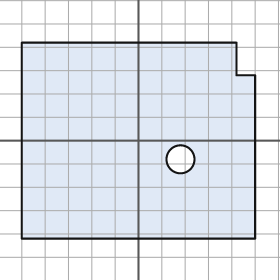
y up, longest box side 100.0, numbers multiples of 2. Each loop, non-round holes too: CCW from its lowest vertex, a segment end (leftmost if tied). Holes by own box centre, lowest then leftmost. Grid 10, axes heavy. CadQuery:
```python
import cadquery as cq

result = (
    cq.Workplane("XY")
    .moveTo(-50.0, -42.0)
    .lineTo(50.0, -42.0)
    .lineTo(50.0, 28.0)
    .lineTo(42.0, 28.0)
    .lineTo(42.0, 42.0)
    .lineTo(-50.0, 42.0)
    .close()
    .moveTo(18.0, -8.0)
    .circle(6.0)
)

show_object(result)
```